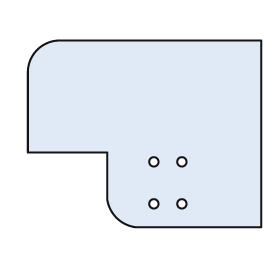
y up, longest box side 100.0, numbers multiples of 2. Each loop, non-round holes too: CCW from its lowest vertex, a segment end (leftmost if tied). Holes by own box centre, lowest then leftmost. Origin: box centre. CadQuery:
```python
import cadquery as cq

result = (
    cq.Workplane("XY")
    .moveTo(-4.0, -40.0)
    .lineTo(50.0, -40.0)
    .lineTo(50.0, 40.0)
    .lineTo(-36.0, 40.0)
    .threePointArc((-46.0, 36.0), (-50.0, 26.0))
    .lineTo(-50.0, -8.0)
    .lineTo(-16.0, -8.0)
    .lineTo(-16.0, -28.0)
    .threePointArc((-12.0, -36.0), (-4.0, -40.0))
    .close()
    .moveTo(4.0, -30.0)
    .circle(2.0)
    .moveTo(16.0, -30.0)
    .circle(2.0)
    .moveTo(4.0, -12.0)
    .circle(2.0)
    .moveTo(16.0, -12.0)
    .circle(2.0)
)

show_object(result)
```